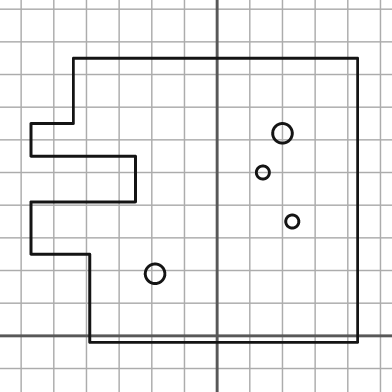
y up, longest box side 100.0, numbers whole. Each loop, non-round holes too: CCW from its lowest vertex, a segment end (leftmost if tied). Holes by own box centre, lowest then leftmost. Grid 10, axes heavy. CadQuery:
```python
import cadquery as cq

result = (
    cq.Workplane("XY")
    .moveTo(-39.0, -2.0)
    .lineTo(43.0, -2.0)
    .lineTo(43.0, 85.0)
    .lineTo(-44.0, 85.0)
    .lineTo(-44.0, 65.0)
    .lineTo(-57.0, 65.0)
    .lineTo(-57.0, 55.0)
    .lineTo(-25.0, 55.0)
    .lineTo(-25.0, 41.0)
    .lineTo(-57.0, 41.0)
    .lineTo(-57.0, 25.0)
    .lineTo(-39.0, 25.0)
    .close()
    .moveTo(-19.0, 19.0)
    .circle(3.0)
    .moveTo(23.0, 35.0)
    .circle(2.0)
    .moveTo(14.0, 50.0)
    .circle(2.0)
    .moveTo(20.0, 62.0)
    .circle(3.0)
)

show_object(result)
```